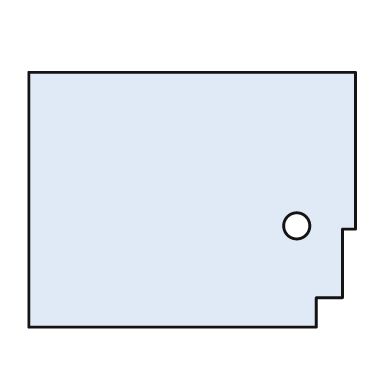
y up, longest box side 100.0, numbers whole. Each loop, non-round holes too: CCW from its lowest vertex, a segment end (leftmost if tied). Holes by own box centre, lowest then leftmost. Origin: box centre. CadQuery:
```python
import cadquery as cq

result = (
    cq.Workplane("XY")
    .moveTo(-50.0, -39.0)
    .lineTo(38.0, -39.0)
    .lineTo(38.0, -30.0)
    .lineTo(46.0, -30.0)
    .lineTo(46.0, -9.0)
    .lineTo(50.0, -9.0)
    .lineTo(50.0, 39.0)
    .lineTo(-50.0, 39.0)
    .close()
    .moveTo(32.0, -8.0)
    .circle(4.0)
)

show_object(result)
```